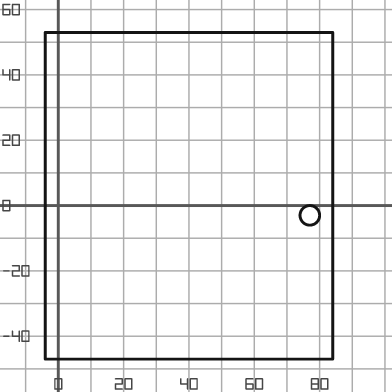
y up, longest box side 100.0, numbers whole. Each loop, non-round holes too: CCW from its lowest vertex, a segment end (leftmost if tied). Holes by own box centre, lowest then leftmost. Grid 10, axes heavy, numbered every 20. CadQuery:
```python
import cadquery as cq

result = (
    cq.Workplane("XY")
    .moveTo(-4.0, -47.0)
    .lineTo(84.0, -47.0)
    .lineTo(84.0, 53.0)
    .lineTo(-4.0, 53.0)
    .close()
    .moveTo(77.0, -3.0)
    .circle(3.0)
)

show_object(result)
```